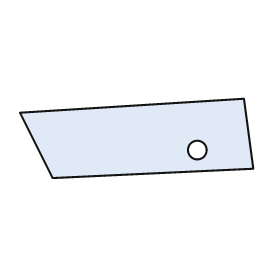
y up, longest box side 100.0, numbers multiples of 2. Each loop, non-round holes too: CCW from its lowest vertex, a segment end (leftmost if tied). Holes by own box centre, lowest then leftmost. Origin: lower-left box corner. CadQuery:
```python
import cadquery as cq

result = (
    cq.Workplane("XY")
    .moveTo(14.0, 0.0)
    .lineTo(100.0, 4.0)
    .lineTo(96.0, 34.0)
    .lineTo(0.0, 28.0)
    .close()
    .moveTo(76.0, 12.0)
    .circle(4.0)
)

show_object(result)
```